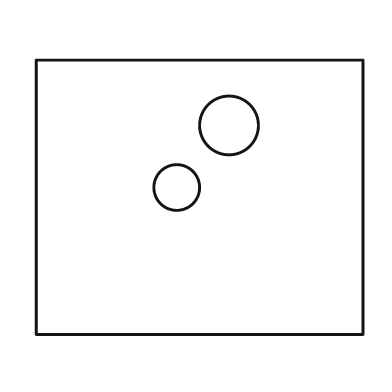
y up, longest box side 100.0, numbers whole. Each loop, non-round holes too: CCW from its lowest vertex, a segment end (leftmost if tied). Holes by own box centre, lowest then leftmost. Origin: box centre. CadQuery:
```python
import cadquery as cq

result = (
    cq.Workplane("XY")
    .moveTo(-50.0, -42.0)
    .lineTo(50.0, -42.0)
    .lineTo(50.0, 42.0)
    .lineTo(-50.0, 42.0)
    .close()
    .moveTo(-7.0, 3.0)
    .circle(7.0)
    .moveTo(9.0, 22.0)
    .circle(9.0)
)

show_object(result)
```